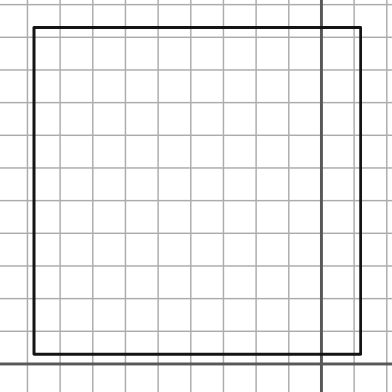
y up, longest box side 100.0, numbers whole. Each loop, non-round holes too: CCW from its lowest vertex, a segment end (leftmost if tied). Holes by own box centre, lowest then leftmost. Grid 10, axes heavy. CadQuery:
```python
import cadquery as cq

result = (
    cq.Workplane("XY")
    .moveTo(-88.0, 3.0)
    .lineTo(12.0, 3.0)
    .lineTo(12.0, 103.0)
    .lineTo(-88.0, 103.0)
    .close()
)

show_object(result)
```